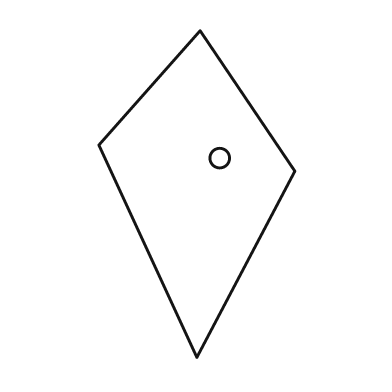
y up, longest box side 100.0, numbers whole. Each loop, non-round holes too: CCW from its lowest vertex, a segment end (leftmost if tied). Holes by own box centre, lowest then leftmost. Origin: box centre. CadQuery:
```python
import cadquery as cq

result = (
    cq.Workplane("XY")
    .moveTo(0.0, -50.0)
    .lineTo(30.0, 7.0)
    .lineTo(1.0, 50.0)
    .lineTo(-30.0, 15.0)
    .close()
    .moveTo(7.0, 11.0)
    .circle(3.0)
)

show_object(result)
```